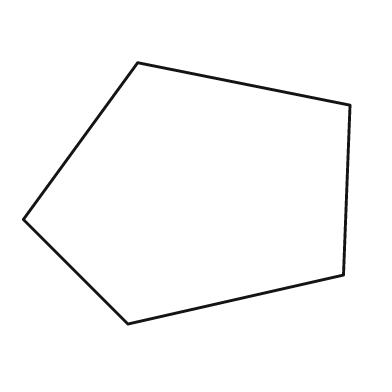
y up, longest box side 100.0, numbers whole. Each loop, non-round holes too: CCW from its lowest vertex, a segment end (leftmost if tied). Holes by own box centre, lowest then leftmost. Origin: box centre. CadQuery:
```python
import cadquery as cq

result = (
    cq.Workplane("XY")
    .moveTo(-18.0, -40.0)
    .lineTo(48.0, -25.0)
    .lineTo(50.0, 27.0)
    .lineTo(-15.0, 40.0)
    .lineTo(-50.0, -8.0)
    .close()
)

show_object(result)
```